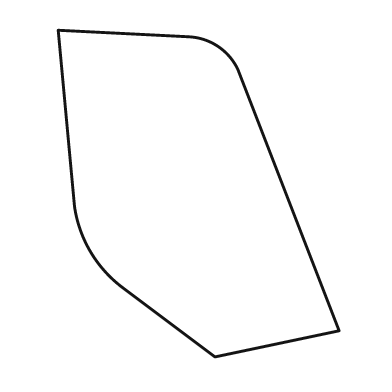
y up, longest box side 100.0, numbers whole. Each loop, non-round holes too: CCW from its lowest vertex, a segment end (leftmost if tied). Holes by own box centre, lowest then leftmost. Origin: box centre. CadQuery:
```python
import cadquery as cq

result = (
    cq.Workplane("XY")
    .moveTo(5.0, -50.0)
    .lineTo(43.0, -42.0)
    .lineTo(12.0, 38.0)
    .threePointArc((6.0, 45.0), (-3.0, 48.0))
    .lineTo(-43.0, 50.0)
    .lineTo(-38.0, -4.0)
    .threePointArc((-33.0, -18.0), (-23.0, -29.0))
    .close()
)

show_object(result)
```